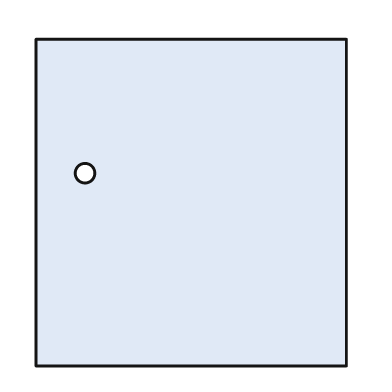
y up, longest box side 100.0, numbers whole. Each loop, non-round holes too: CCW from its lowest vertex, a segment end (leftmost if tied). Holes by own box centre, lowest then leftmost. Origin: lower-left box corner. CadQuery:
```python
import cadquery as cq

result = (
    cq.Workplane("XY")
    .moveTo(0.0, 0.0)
    .lineTo(95.0, 0.0)
    .lineTo(95.0, 100.0)
    .lineTo(0.0, 100.0)
    .close()
    .moveTo(15.0, 59.0)
    .circle(3.0)
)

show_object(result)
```